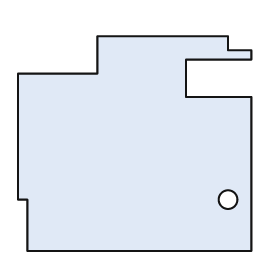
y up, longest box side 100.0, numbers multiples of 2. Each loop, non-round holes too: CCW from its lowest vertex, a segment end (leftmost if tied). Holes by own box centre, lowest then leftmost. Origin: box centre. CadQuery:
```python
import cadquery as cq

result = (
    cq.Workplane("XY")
    .moveTo(-46.0, -46.0)
    .lineTo(50.0, -46.0)
    .lineTo(50.0, 20.0)
    .lineTo(22.0, 20.0)
    .lineTo(22.0, 36.0)
    .lineTo(50.0, 36.0)
    .lineTo(50.0, 40.0)
    .lineTo(40.0, 40.0)
    .lineTo(40.0, 46.0)
    .lineTo(-16.0, 46.0)
    .lineTo(-16.0, 30.0)
    .lineTo(-50.0, 30.0)
    .lineTo(-50.0, -24.0)
    .lineTo(-46.0, -24.0)
    .close()
    .moveTo(40.0, -24.0)
    .circle(4.0)
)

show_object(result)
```